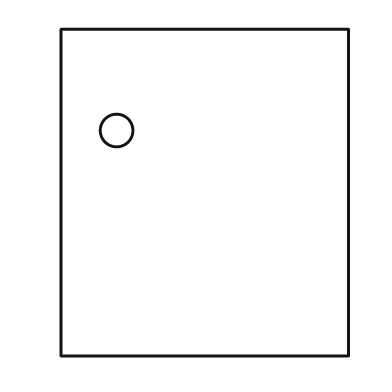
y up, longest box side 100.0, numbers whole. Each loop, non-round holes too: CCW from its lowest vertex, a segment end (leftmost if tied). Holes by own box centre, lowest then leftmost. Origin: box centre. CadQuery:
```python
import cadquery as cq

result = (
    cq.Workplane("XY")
    .moveTo(-44.0, -50.0)
    .lineTo(44.0, -50.0)
    .lineTo(44.0, 50.0)
    .lineTo(-44.0, 50.0)
    .close()
    .moveTo(-27.0, 19.0)
    .circle(5.0)
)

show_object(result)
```